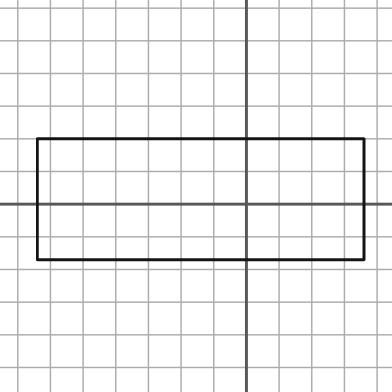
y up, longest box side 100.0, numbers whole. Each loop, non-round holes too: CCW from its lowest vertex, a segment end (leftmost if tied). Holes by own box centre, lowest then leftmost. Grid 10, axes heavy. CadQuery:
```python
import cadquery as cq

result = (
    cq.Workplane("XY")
    .moveTo(-64.0, -17.0)
    .lineTo(36.0, -17.0)
    .lineTo(36.0, 20.0)
    .lineTo(-64.0, 20.0)
    .close()
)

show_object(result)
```